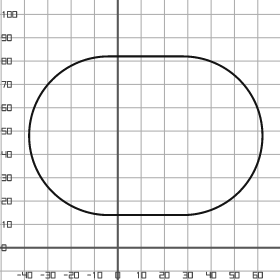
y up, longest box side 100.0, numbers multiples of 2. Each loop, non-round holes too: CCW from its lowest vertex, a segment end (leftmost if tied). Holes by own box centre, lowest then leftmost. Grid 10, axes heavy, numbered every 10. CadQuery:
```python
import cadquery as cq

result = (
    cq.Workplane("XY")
    .moveTo(-4.0, 14.0)
    .lineTo(28.0, 14.0)
    .threePointArc((62.0, 48.0), (28.0, 82.0))
    .lineTo(-4.0, 82.0)
    .threePointArc((-38.0, 48.0), (-4.0, 14.0))
    .close()
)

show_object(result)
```